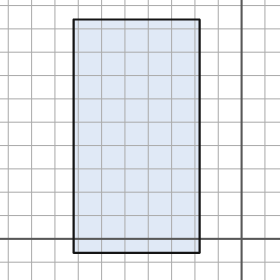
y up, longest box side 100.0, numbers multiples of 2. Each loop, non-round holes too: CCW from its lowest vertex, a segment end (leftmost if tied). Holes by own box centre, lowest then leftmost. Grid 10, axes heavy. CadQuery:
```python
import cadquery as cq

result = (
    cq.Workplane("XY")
    .moveTo(-72.0, -6.0)
    .lineTo(-18.0, -6.0)
    .lineTo(-18.0, 94.0)
    .lineTo(-72.0, 94.0)
    .close()
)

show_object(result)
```